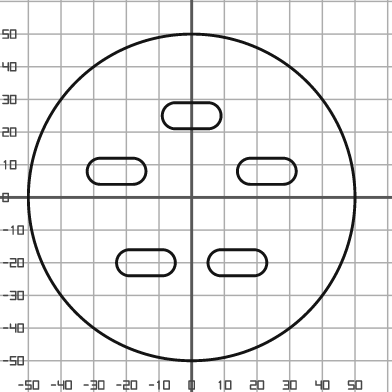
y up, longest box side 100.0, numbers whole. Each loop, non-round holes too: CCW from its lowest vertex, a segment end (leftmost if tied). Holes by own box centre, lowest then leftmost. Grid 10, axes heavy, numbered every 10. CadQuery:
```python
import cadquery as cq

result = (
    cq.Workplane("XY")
    .moveTo(0.0, 0.0)
    .circle(50.0)
    .moveTo(-19.0, -24.0)
    .lineTo(-9.0, -24.0)
    .threePointArc((-5.0, -20.0), (-9.0, -16.0))
    .lineTo(-19.0, -16.0)
    .threePointArc((-23.0, -20.0), (-19.0, -24.0))
    .close()
    .moveTo(9.0, -24.0)
    .lineTo(19.0, -24.0)
    .threePointArc((23.0, -20.0), (19.0, -16.0))
    .lineTo(9.0, -16.0)
    .threePointArc((5.0, -20.0), (9.0, -24.0))
    .close()
    .moveTo(-28.0, 4.0)
    .lineTo(-18.0, 4.0)
    .threePointArc((-14.0, 8.0), (-18.0, 12.0))
    .lineTo(-28.0, 12.0)
    .threePointArc((-32.0, 8.0), (-28.0, 4.0))
    .close()
    .moveTo(18.0, 4.0)
    .lineTo(28.0, 4.0)
    .threePointArc((32.0, 8.0), (28.0, 12.0))
    .lineTo(18.0, 12.0)
    .threePointArc((14.0, 8.0), (18.0, 4.0))
    .close()
    .moveTo(-5.0, 21.0)
    .lineTo(5.0, 21.0)
    .threePointArc((9.0, 25.0), (5.0, 29.0))
    .lineTo(-5.0, 29.0)
    .threePointArc((-9.0, 25.0), (-5.0, 21.0))
    .close()
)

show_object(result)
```